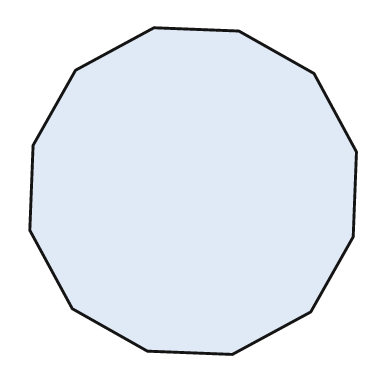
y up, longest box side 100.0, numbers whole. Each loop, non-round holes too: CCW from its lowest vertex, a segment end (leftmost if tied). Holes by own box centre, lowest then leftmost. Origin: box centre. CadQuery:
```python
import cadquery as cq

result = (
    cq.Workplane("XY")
    .moveTo(12.0, -50.0)
    .lineTo(36.0, -37.0)
    .lineTo(49.0, -14.0)
    .lineTo(50.0, 12.0)
    .lineTo(37.0, 36.0)
    .lineTo(14.0, 49.0)
    .lineTo(-12.0, 50.0)
    .lineTo(-36.0, 37.0)
    .lineTo(-49.0, 14.0)
    .lineTo(-50.0, -12.0)
    .lineTo(-37.0, -36.0)
    .lineTo(-14.0, -49.0)
    .close()
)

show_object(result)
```